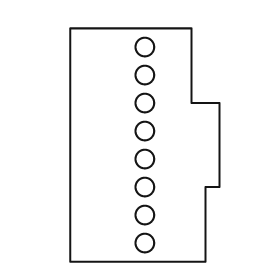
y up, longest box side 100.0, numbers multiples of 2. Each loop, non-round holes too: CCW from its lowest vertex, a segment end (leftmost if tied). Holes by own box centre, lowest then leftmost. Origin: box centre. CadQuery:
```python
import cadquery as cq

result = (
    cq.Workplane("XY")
    .moveTo(-32.0, -50.0)
    .lineTo(26.0, -50.0)
    .lineTo(26.0, -18.0)
    .lineTo(32.0, -18.0)
    .lineTo(32.0, 18.0)
    .lineTo(20.0, 18.0)
    .lineTo(20.0, 50.0)
    .lineTo(-32.0, 50.0)
    .close()
    .moveTo(0.0, -42.0)
    .circle(4.0)
    .moveTo(0.0, -30.0)
    .circle(4.0)
    .moveTo(0.0, -18.0)
    .circle(4.0)
    .moveTo(0.0, -6.0)
    .circle(4.0)
    .moveTo(0.0, 6.0)
    .circle(4.0)
    .moveTo(0.0, 18.0)
    .circle(4.0)
    .moveTo(0.0, 30.0)
    .circle(4.0)
    .moveTo(0.0, 42.0)
    .circle(4.0)
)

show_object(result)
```